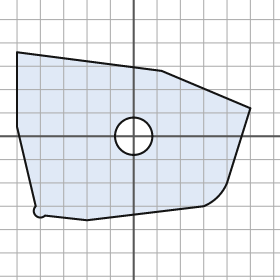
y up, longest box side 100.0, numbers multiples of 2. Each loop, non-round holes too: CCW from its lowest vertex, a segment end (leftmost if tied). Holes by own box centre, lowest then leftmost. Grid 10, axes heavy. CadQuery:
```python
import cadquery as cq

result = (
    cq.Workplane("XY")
    .moveTo(-20.0, -36.0)
    .lineTo(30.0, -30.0)
    .threePointArc((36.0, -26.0), (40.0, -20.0))
    .lineTo(50.0, 12.0)
    .lineTo(12.0, 28.0)
    .lineTo(-50.0, 36.0)
    .lineTo(-50.0, 4.0)
    .lineTo(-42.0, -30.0)
    .threePointArc((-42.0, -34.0), (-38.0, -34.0))
    .close()
    .moveTo(0.0, 0.0)
    .circle(8.0)
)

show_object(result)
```